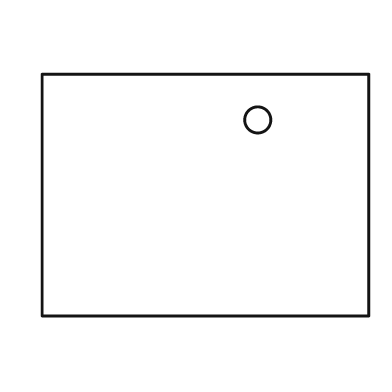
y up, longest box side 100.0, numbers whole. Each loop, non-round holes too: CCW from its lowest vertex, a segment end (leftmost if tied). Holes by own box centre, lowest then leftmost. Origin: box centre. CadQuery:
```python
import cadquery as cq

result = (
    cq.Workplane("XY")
    .moveTo(-50.0, -37.0)
    .lineTo(50.0, -37.0)
    .lineTo(50.0, 37.0)
    .lineTo(-50.0, 37.0)
    .close()
    .moveTo(16.0, 23.0)
    .circle(4.0)
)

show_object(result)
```